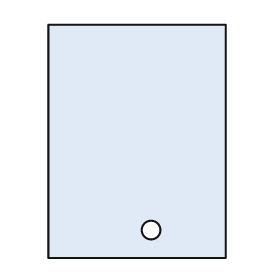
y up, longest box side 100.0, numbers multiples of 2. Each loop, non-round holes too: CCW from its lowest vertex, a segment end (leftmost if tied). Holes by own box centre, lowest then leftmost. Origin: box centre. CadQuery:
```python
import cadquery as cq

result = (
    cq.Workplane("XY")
    .moveTo(-38.0, -50.0)
    .lineTo(38.0, -50.0)
    .lineTo(38.0, 50.0)
    .lineTo(-38.0, 50.0)
    .close()
    .moveTo(6.0, -38.0)
    .circle(4.0)
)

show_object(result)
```